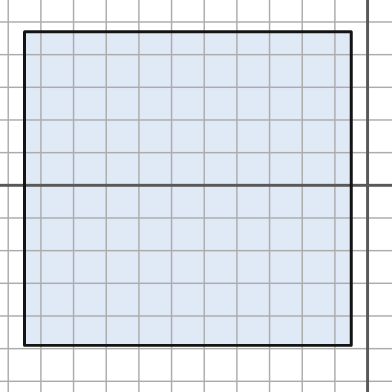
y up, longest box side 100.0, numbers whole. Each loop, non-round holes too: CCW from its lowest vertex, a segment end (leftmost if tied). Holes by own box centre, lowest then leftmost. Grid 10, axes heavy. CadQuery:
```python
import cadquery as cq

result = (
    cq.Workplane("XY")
    .moveTo(-105.0, -49.0)
    .lineTo(-5.0, -49.0)
    .lineTo(-5.0, 47.0)
    .lineTo(-105.0, 47.0)
    .close()
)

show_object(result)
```